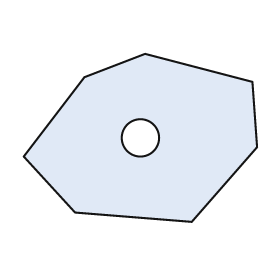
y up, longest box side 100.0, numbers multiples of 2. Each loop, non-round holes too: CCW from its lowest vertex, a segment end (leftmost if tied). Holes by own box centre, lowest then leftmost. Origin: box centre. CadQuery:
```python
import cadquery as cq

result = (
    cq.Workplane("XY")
    .moveTo(22.0, -36.0)
    .lineTo(50.0, -4.0)
    .lineTo(48.0, 24.0)
    .lineTo(2.0, 36.0)
    .lineTo(-24.0, 26.0)
    .lineTo(-50.0, -8.0)
    .lineTo(-28.0, -32.0)
    .close()
    .moveTo(0.0, 0.0)
    .circle(8.0)
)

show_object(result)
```